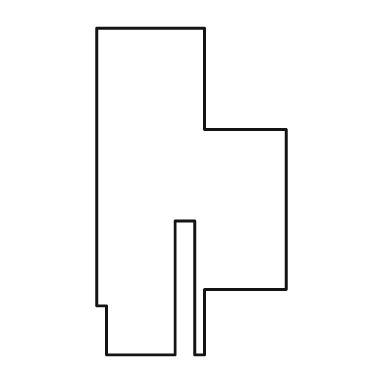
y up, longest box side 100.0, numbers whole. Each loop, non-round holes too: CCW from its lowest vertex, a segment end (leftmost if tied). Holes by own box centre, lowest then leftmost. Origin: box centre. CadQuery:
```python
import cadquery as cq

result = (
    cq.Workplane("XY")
    .moveTo(-26.0, -50.0)
    .lineTo(-5.0, -50.0)
    .lineTo(-5.0, -9.0)
    .lineTo(1.0, -9.0)
    .lineTo(1.0, -50.0)
    .lineTo(4.0, -50.0)
    .lineTo(4.0, -30.0)
    .lineTo(29.0, -30.0)
    .lineTo(29.0, 19.0)
    .lineTo(4.0, 19.0)
    .lineTo(4.0, 50.0)
    .lineTo(-29.0, 50.0)
    .lineTo(-29.0, -35.0)
    .lineTo(-26.0, -35.0)
    .close()
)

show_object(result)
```